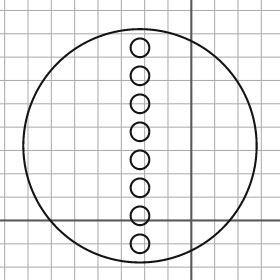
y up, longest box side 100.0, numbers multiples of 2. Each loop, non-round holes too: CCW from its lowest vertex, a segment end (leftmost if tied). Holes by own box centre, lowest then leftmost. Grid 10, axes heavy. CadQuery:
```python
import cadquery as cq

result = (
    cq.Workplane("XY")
    .moveTo(-22.0, 32.0)
    .circle(50.0)
    .moveTo(-22.0, -10.0)
    .circle(4.0)
    .moveTo(-22.0, 2.0)
    .circle(4.0)
    .moveTo(-22.0, 14.0)
    .circle(4.0)
    .moveTo(-22.0, 26.0)
    .circle(4.0)
    .moveTo(-22.0, 38.0)
    .circle(4.0)
    .moveTo(-22.0, 50.0)
    .circle(4.0)
    .moveTo(-22.0, 62.0)
    .circle(4.0)
    .moveTo(-22.0, 74.0)
    .circle(4.0)
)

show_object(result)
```